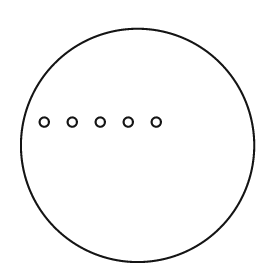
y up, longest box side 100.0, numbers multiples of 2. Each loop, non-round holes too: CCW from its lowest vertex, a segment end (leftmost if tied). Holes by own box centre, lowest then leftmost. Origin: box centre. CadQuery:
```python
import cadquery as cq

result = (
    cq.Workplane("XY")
    .moveTo(0.0, 0.0)
    .circle(50.0)
    .moveTo(-40.0, 10.0)
    .circle(2.0)
    .moveTo(-28.0, 10.0)
    .circle(2.0)
    .moveTo(-16.0, 10.0)
    .circle(2.0)
    .moveTo(-4.0, 10.0)
    .circle(2.0)
    .moveTo(8.0, 10.0)
    .circle(2.0)
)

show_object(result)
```